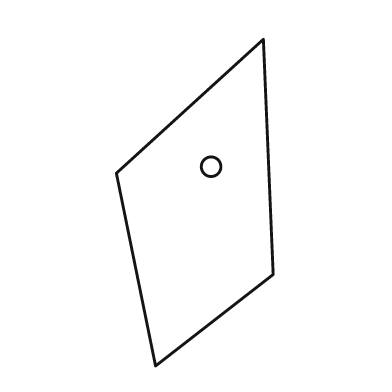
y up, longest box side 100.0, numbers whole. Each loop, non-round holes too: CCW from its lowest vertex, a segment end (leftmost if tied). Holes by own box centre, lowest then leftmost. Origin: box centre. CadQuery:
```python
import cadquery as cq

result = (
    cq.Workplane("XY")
    .moveTo(-12.0, -50.0)
    .lineTo(24.0, -22.0)
    .lineTo(21.0, 50.0)
    .lineTo(-24.0, 9.0)
    .close()
    .moveTo(5.0, 11.0)
    .circle(3.0)
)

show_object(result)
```